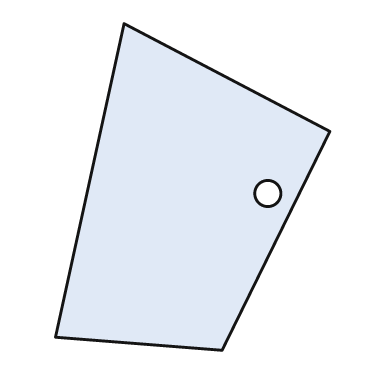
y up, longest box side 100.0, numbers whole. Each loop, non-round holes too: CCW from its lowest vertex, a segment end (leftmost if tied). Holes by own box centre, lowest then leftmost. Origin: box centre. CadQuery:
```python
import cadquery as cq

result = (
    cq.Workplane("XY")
    .moveTo(9.0, -50.0)
    .lineTo(42.0, 17.0)
    .lineTo(-21.0, 50.0)
    .lineTo(-42.0, -46.0)
    .close()
    .moveTo(23.0, -2.0)
    .circle(4.0)
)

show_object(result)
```